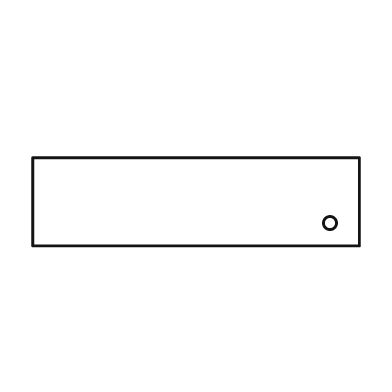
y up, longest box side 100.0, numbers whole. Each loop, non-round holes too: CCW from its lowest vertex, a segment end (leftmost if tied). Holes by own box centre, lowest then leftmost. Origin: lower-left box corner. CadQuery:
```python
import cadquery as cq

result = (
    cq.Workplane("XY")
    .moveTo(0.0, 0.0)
    .lineTo(100.0, 0.0)
    .lineTo(100.0, 27.0)
    .lineTo(0.0, 27.0)
    .close()
    .moveTo(91.0, 7.0)
    .circle(2.0)
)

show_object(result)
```